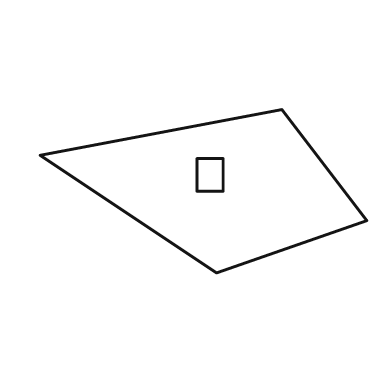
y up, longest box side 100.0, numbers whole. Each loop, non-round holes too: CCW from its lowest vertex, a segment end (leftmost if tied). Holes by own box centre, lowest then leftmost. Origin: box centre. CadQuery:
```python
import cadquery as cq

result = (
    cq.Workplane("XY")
    .moveTo(4.0, -25.0)
    .lineTo(50.0, -9.0)
    .lineTo(24.0, 25.0)
    .lineTo(-50.0, 11.0)
    .close()
    .moveTo(-2.0, 0.0)
    .lineTo(6.0, 0.0)
    .lineTo(6.0, 10.0)
    .lineTo(-2.0, 10.0)
    .close()
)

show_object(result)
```